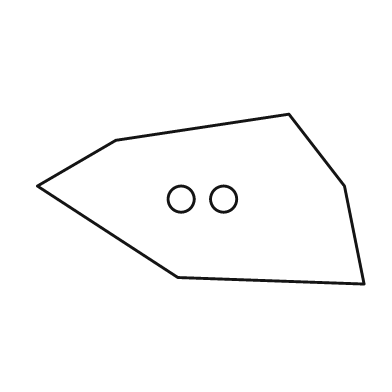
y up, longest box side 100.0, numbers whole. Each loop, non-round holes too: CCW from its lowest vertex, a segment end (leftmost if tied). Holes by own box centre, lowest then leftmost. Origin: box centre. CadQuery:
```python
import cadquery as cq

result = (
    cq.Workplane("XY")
    .moveTo(50.0, -26.0)
    .lineTo(44.0, 4.0)
    .lineTo(27.0, 26.0)
    .lineTo(-26.0, 18.0)
    .lineTo(-50.0, 4.0)
    .lineTo(-7.0, -24.0)
    .close()
    .moveTo(-6.0, 0.0)
    .circle(4.0)
    .moveTo(7.0, 0.0)
    .circle(4.0)
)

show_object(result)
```